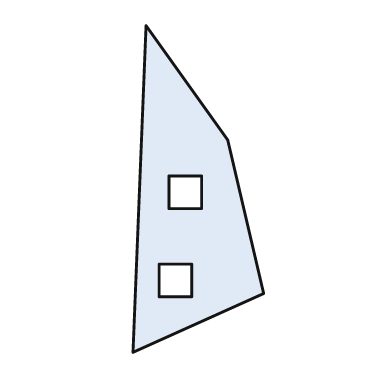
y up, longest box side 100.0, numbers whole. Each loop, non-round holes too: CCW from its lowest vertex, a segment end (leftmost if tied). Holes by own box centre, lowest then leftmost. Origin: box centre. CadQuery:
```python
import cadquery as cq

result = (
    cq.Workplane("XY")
    .moveTo(-20.0, -50.0)
    .lineTo(20.0, -32.0)
    .lineTo(9.0, 15.0)
    .lineTo(-16.0, 50.0)
    .close()
    .moveTo(-12.0, -33.0)
    .lineTo(-2.0, -33.0)
    .lineTo(-2.0, -23.0)
    .lineTo(-12.0, -23.0)
    .close()
    .moveTo(-9.0, -6.0)
    .lineTo(1.0, -6.0)
    .lineTo(1.0, 4.0)
    .lineTo(-9.0, 4.0)
    .close()
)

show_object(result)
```